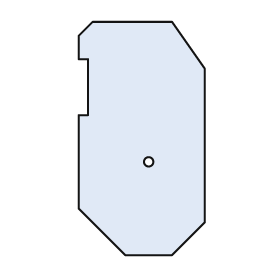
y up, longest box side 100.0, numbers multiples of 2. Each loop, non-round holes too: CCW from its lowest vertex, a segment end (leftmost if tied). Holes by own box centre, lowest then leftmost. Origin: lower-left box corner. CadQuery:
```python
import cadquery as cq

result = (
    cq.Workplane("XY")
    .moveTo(20.0, 0.0)
    .lineTo(40.0, 0.0)
    .lineTo(54.0, 14.0)
    .lineTo(54.0, 80.0)
    .lineTo(40.0, 100.0)
    .lineTo(6.0, 100.0)
    .lineTo(0.0, 94.0)
    .lineTo(0.0, 84.0)
    .lineTo(4.0, 84.0)
    .lineTo(4.0, 60.0)
    .lineTo(0.0, 60.0)
    .lineTo(0.0, 20.0)
    .close()
    .moveTo(30.0, 40.0)
    .circle(2.0)
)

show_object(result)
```